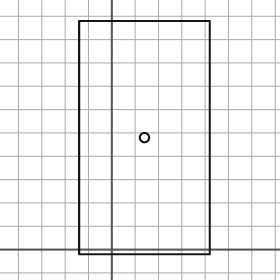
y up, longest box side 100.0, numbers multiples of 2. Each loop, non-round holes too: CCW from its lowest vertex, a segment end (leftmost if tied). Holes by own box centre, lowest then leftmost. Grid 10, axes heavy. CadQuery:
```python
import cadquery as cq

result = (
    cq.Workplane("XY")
    .moveTo(-14.0, -2.0)
    .lineTo(42.0, -2.0)
    .lineTo(42.0, 98.0)
    .lineTo(-14.0, 98.0)
    .close()
    .moveTo(14.0, 48.0)
    .circle(2.0)
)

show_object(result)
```